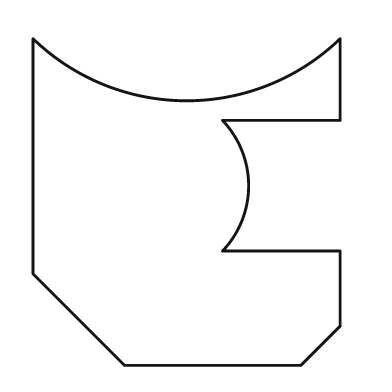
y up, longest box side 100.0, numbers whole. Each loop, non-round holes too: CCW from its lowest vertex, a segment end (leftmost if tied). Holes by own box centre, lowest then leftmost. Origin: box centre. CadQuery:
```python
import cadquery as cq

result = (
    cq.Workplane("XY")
    .moveTo(-19.0, -50.0)
    .lineTo(35.0, -50.0)
    .lineTo(47.0, -38.0)
    .lineTo(47.0, -15.0)
    .lineTo(11.0, -15.0)
    .threePointArc((19.0, 5.0), (11.0, 25.0))
    .lineTo(47.0, 25.0)
    .lineTo(47.0, 50.0)
    .threePointArc((0.0, 31.0), (-47.0, 50.0))
    .lineTo(-47.0, -22.0)
    .close()
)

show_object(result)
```